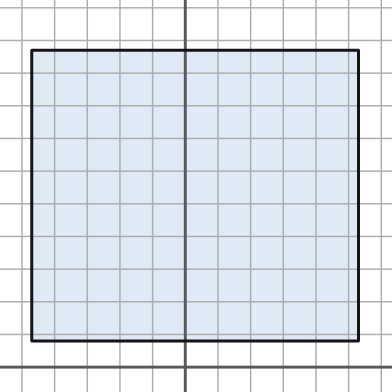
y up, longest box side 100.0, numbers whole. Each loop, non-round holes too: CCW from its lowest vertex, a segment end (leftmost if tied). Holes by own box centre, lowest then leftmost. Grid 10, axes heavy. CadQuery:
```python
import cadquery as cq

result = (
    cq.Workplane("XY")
    .moveTo(-47.0, 8.0)
    .lineTo(53.0, 8.0)
    .lineTo(53.0, 97.0)
    .lineTo(-47.0, 97.0)
    .close()
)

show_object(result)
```